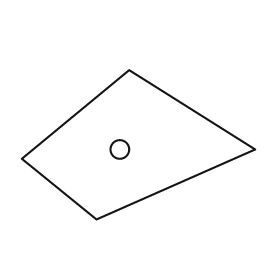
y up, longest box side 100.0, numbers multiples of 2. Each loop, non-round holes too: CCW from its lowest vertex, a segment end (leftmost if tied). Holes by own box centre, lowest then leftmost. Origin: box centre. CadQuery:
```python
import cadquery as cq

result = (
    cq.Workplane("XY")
    .moveTo(-18.0, -32.0)
    .lineTo(50.0, -2.0)
    .lineTo(-4.0, 32.0)
    .lineTo(-50.0, -6.0)
    .close()
    .moveTo(-8.0, -2.0)
    .circle(4.0)
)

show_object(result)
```